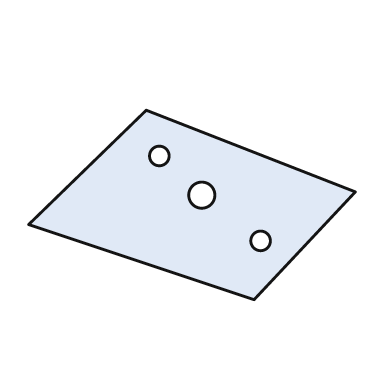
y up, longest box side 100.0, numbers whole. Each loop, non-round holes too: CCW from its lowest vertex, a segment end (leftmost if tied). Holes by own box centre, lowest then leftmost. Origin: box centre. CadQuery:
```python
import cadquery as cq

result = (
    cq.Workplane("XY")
    .moveTo(19.0, -29.0)
    .lineTo(50.0, 4.0)
    .lineTo(-14.0, 29.0)
    .lineTo(-50.0, -6.0)
    .close()
    .moveTo(21.0, -11.0)
    .circle(3.0)
    .moveTo(3.0, 3.0)
    .circle(4.0)
    .moveTo(-10.0, 15.0)
    .circle(3.0)
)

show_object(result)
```